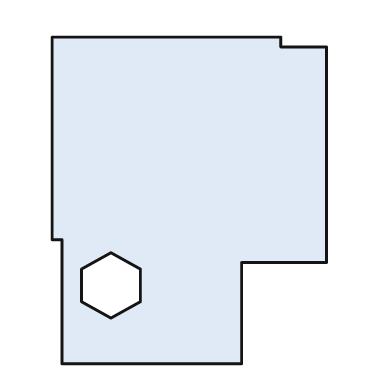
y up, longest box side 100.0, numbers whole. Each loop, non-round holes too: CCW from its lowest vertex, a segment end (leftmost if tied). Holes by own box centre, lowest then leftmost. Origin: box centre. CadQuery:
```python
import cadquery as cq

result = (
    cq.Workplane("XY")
    .moveTo(-39.0, -50.0)
    .lineTo(16.0, -50.0)
    .lineTo(16.0, -19.0)
    .lineTo(42.0, -19.0)
    .lineTo(42.0, 47.0)
    .lineTo(28.0, 47.0)
    .lineTo(28.0, 50.0)
    .lineTo(-42.0, 50.0)
    .lineTo(-42.0, -12.0)
    .lineTo(-39.0, -12.0)
    .close()
    .moveTo(-24.0, -36.0)
    .lineTo(-15.0, -31.0)
    .lineTo(-15.0, -21.0)
    .lineTo(-24.0, -16.0)
    .lineTo(-33.0, -21.0)
    .lineTo(-33.0, -31.0)
    .close()
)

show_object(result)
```